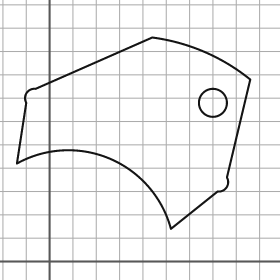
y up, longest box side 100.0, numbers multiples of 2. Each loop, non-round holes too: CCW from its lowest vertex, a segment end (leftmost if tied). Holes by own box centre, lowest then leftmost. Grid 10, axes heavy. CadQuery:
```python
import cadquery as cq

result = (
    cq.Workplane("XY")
    .moveTo(52.0, 14.0)
    .lineTo(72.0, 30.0)
    .threePointArc((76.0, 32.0), (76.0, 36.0))
    .lineTo(86.0, 78.0)
    .threePointArc((66.0, 90.0), (44.0, 96.0))
    .lineTo(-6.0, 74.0)
    .threePointArc((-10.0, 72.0), (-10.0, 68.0))
    .lineTo(-14.0, 42.0)
    .threePointArc((26.0, 44.0), (52.0, 14.0))
    .close()
    .moveTo(70.0, 68.0)
    .circle(6.0)
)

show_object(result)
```